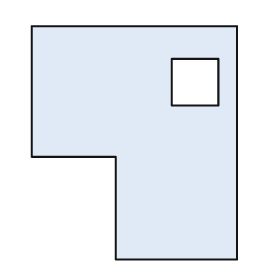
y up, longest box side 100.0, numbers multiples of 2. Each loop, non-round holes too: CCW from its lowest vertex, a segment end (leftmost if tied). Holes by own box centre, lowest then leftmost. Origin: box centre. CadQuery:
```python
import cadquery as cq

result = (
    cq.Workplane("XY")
    .moveTo(-8.0, -50.0)
    .lineTo(44.0, -50.0)
    .lineTo(44.0, 50.0)
    .lineTo(-44.0, 50.0)
    .lineTo(-44.0, -6.0)
    .lineTo(-8.0, -6.0)
    .close()
    .moveTo(16.0, 16.0)
    .lineTo(36.0, 16.0)
    .lineTo(36.0, 36.0)
    .lineTo(16.0, 36.0)
    .close()
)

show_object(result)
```